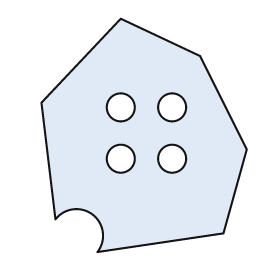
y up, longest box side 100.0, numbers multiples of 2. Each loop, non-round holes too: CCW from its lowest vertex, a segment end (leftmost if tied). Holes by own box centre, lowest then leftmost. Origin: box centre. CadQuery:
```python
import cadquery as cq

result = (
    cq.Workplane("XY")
    .moveTo(-20.0, -50.0)
    .lineTo(34.0, -42.0)
    .lineTo(44.0, -6.0)
    .lineTo(24.0, 34.0)
    .lineTo(-10.0, 50.0)
    .lineTo(-44.0, 14.0)
    .lineTo(-38.0, -36.0)
    .threePointArc((-22.0, -34.0), (-20.0, -50.0))
    .close()
    .moveTo(-10.0, -10.0)
    .circle(6.0)
    .moveTo(12.0, -10.0)
    .circle(6.0)
    .moveTo(-10.0, 12.0)
    .circle(6.0)
    .moveTo(12.0, 12.0)
    .circle(6.0)
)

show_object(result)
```